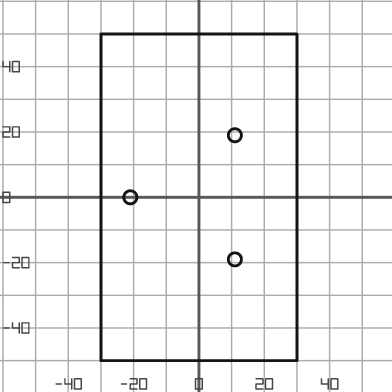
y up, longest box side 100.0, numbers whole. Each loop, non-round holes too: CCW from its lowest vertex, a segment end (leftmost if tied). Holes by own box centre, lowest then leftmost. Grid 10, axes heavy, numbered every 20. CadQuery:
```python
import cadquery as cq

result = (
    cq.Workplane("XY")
    .moveTo(-30.0, -50.0)
    .lineTo(30.0, -50.0)
    .lineTo(30.0, 50.0)
    .lineTo(-30.0, 50.0)
    .close()
    .moveTo(11.0, -19.0)
    .circle(2.0)
    .moveTo(-21.0, 0.0)
    .circle(2.0)
    .moveTo(11.0, 19.0)
    .circle(2.0)
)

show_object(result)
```